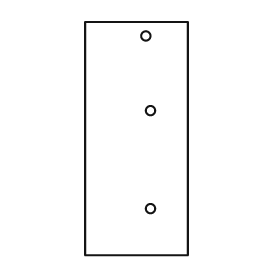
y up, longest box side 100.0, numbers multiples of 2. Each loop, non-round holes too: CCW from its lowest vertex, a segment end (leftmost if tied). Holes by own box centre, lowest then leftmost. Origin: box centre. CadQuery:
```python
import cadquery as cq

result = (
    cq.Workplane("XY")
    .moveTo(-22.0, -50.0)
    .lineTo(22.0, -50.0)
    .lineTo(22.0, 50.0)
    .lineTo(-22.0, 50.0)
    .close()
    .moveTo(6.0, -30.0)
    .circle(2.0)
    .moveTo(6.0, 12.0)
    .circle(2.0)
    .moveTo(4.0, 44.0)
    .circle(2.0)
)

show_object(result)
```